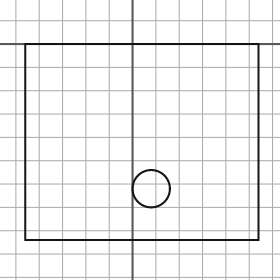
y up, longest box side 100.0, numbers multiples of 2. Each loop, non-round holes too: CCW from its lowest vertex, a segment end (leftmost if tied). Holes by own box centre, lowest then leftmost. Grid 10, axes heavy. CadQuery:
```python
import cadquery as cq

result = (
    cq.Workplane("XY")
    .moveTo(-46.0, -84.0)
    .lineTo(54.0, -84.0)
    .lineTo(54.0, 0.0)
    .lineTo(-46.0, 0.0)
    .close()
    .moveTo(8.0, -62.0)
    .circle(8.0)
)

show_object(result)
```